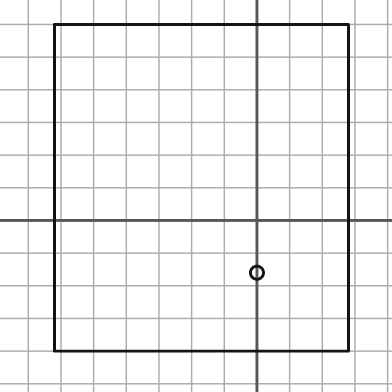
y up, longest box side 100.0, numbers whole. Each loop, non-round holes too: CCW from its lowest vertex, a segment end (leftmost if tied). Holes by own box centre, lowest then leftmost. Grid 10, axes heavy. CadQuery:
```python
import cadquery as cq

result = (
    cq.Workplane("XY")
    .moveTo(-62.0, -40.0)
    .lineTo(28.0, -40.0)
    .lineTo(28.0, 60.0)
    .lineTo(-62.0, 60.0)
    .close()
    .moveTo(0.0, -16.0)
    .circle(2.0)
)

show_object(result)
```